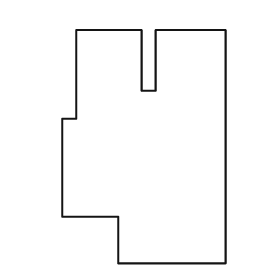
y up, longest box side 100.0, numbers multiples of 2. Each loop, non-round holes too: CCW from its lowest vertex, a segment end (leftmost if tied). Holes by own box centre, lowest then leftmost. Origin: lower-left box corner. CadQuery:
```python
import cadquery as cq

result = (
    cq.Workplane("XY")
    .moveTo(24.0, 0.0)
    .lineTo(70.0, 0.0)
    .lineTo(70.0, 100.0)
    .lineTo(40.0, 100.0)
    .lineTo(40.0, 74.0)
    .lineTo(34.0, 74.0)
    .lineTo(34.0, 100.0)
    .lineTo(6.0, 100.0)
    .lineTo(6.0, 62.0)
    .lineTo(0.0, 62.0)
    .lineTo(0.0, 20.0)
    .lineTo(24.0, 20.0)
    .close()
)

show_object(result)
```